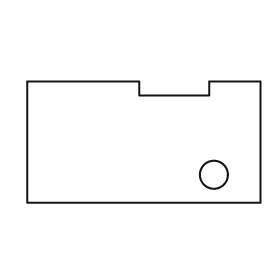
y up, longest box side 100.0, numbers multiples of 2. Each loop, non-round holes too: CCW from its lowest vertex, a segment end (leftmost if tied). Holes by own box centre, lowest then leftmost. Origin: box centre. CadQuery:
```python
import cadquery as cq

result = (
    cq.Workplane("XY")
    .moveTo(-50.0, -26.0)
    .lineTo(50.0, -26.0)
    .lineTo(50.0, 26.0)
    .lineTo(28.0, 26.0)
    .lineTo(28.0, 20.0)
    .lineTo(-2.0, 20.0)
    .lineTo(-2.0, 26.0)
    .lineTo(-50.0, 26.0)
    .close()
    .moveTo(30.0, -14.0)
    .circle(6.0)
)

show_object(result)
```